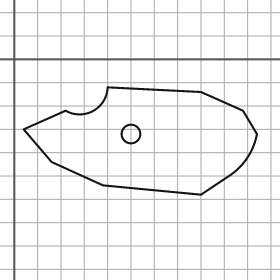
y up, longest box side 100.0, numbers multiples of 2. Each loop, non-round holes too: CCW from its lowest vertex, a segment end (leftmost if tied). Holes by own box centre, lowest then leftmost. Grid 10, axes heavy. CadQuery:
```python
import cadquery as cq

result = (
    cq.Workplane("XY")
    .moveTo(80.0, -58.0)
    .lineTo(92.0, -50.0)
    .threePointArc((100.0, -42.0), (104.0, -32.0))
    .lineTo(98.0, -22.0)
    .lineTo(80.0, -14.0)
    .lineTo(40.0, -12.0)
    .threePointArc((34.0, -22.0), (22.0, -22.0))
    .lineTo(4.0, -30.0)
    .lineTo(16.0, -44.0)
    .lineTo(38.0, -54.0)
    .close()
    .moveTo(50.0, -32.0)
    .circle(4.0)
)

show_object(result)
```